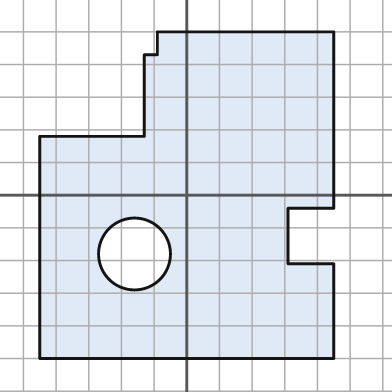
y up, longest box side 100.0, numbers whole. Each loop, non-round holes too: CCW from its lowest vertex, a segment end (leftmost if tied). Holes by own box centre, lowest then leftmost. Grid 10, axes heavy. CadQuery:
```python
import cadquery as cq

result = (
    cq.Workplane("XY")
    .moveTo(-45.0, -50.0)
    .lineTo(45.0, -50.0)
    .lineTo(45.0, -21.0)
    .lineTo(31.0, -21.0)
    .lineTo(31.0, -4.0)
    .lineTo(45.0, -4.0)
    .lineTo(45.0, 50.0)
    .lineTo(-9.0, 50.0)
    .lineTo(-9.0, 43.0)
    .lineTo(-13.0, 43.0)
    .lineTo(-13.0, 18.0)
    .lineTo(-45.0, 18.0)
    .close()
    .moveTo(-16.0, -18.0)
    .circle(11.0)
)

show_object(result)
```